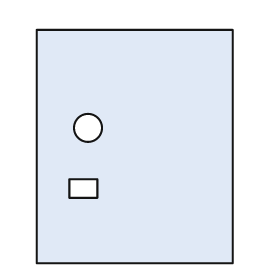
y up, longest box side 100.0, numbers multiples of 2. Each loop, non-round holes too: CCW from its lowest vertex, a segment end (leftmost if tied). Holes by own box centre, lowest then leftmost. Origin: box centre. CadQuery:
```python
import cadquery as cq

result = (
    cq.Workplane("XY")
    .moveTo(-42.0, -50.0)
    .lineTo(42.0, -50.0)
    .lineTo(42.0, 50.0)
    .lineTo(-42.0, 50.0)
    .close()
    .moveTo(-28.0, -22.0)
    .lineTo(-16.0, -22.0)
    .lineTo(-16.0, -14.0)
    .lineTo(-28.0, -14.0)
    .close()
    .moveTo(-20.0, 8.0)
    .circle(6.0)
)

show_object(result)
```